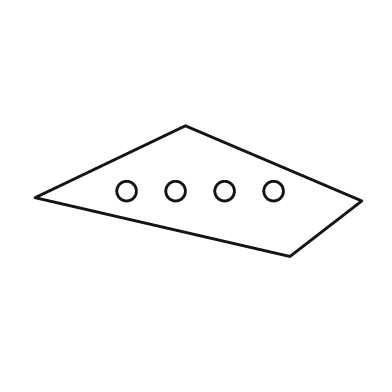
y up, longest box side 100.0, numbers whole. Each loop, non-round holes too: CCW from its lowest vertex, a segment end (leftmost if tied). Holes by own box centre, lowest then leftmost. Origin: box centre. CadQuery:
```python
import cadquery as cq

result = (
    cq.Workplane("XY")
    .moveTo(28.0, -20.0)
    .lineTo(50.0, -3.0)
    .lineTo(-4.0, 20.0)
    .lineTo(-50.0, -2.0)
    .close()
    .moveTo(-22.0, 0.0)
    .circle(3.0)
    .moveTo(-7.0, 0.0)
    .circle(3.0)
    .moveTo(8.0, 0.0)
    .circle(3.0)
    .moveTo(23.0, 0.0)
    .circle(3.0)
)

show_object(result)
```